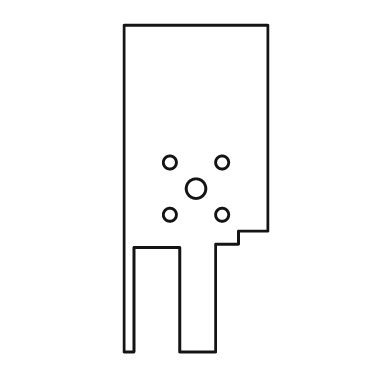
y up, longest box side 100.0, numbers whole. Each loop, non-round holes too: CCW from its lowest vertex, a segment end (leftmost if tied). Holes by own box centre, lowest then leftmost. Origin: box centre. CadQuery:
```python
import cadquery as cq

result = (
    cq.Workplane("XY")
    .moveTo(-22.0, -50.0)
    .lineTo(-19.0, -50.0)
    .lineTo(-19.0, -18.0)
    .lineTo(-5.0, -18.0)
    .lineTo(-5.0, -50.0)
    .lineTo(6.0, -50.0)
    .lineTo(6.0, -17.0)
    .lineTo(13.0, -17.0)
    .lineTo(13.0, -13.0)
    .lineTo(22.0, -13.0)
    .lineTo(22.0, 50.0)
    .lineTo(-22.0, 50.0)
    .close()
    .moveTo(-8.0, -8.0)
    .circle(2.0)
    .moveTo(8.0, -8.0)
    .circle(2.0)
    .moveTo(0.0, 0.0)
    .circle(3.0)
    .moveTo(-8.0, 8.0)
    .circle(2.0)
    .moveTo(8.0, 8.0)
    .circle(2.0)
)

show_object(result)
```